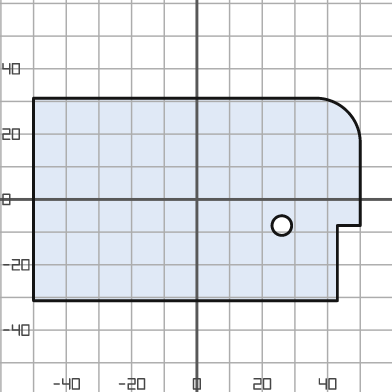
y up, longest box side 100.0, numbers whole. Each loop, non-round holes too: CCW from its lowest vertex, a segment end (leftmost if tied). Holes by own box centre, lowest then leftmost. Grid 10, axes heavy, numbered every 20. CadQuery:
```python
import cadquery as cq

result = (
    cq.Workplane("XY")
    .moveTo(-50.0, -31.0)
    .lineTo(43.0, -31.0)
    .lineTo(43.0, -8.0)
    .lineTo(50.0, -8.0)
    .lineTo(50.0, 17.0)
    .threePointArc((46.0, 27.0), (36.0, 31.0))
    .lineTo(-50.0, 31.0)
    .close()
    .moveTo(26.0, -8.0)
    .circle(3.0)
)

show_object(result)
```